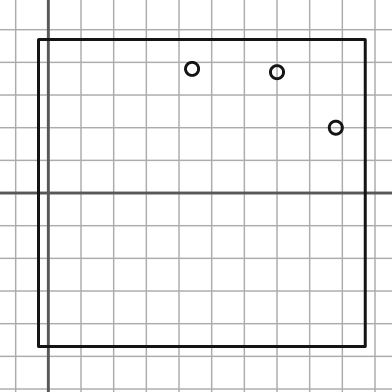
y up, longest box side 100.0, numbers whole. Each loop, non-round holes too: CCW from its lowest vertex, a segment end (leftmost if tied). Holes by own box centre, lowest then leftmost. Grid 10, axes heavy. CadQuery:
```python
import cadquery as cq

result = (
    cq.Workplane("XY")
    .moveTo(-3.0, -47.0)
    .lineTo(97.0, -47.0)
    .lineTo(97.0, 47.0)
    .lineTo(-3.0, 47.0)
    .close()
    .moveTo(88.0, 20.0)
    .circle(2.0)
    .moveTo(70.0, 37.0)
    .circle(2.0)
    .moveTo(44.0, 38.0)
    .circle(2.0)
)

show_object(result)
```